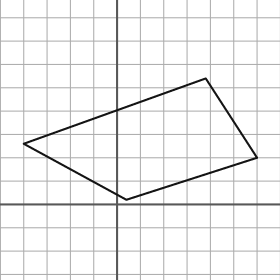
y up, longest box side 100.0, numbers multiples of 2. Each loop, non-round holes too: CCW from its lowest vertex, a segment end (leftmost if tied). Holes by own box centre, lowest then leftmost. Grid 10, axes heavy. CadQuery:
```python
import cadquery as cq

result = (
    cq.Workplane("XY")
    .moveTo(4.0, 2.0)
    .lineTo(60.0, 20.0)
    .lineTo(38.0, 54.0)
    .lineTo(-40.0, 26.0)
    .close()
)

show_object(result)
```